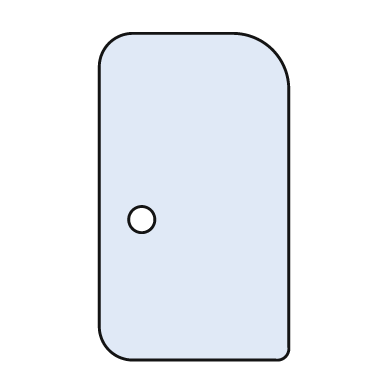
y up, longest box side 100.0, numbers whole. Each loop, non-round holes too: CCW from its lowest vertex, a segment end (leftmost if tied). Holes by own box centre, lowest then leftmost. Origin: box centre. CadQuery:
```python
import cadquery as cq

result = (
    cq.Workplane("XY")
    .moveTo(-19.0, -50.0)
    .lineTo(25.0, -50.0)
    .threePointArc((28.0, -49.0), (29.0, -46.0))
    .lineTo(29.0, 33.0)
    .threePointArc((24.0, 45.0), (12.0, 50.0))
    .lineTo(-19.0, 50.0)
    .threePointArc((-26.0, 47.0), (-29.0, 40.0))
    .lineTo(-29.0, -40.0)
    .threePointArc((-26.0, -47.0), (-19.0, -50.0))
    .close()
    .moveTo(-16.0, -7.0)
    .circle(4.0)
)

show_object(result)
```